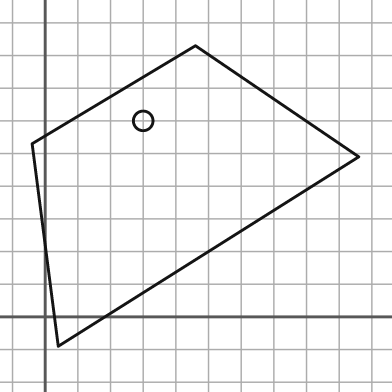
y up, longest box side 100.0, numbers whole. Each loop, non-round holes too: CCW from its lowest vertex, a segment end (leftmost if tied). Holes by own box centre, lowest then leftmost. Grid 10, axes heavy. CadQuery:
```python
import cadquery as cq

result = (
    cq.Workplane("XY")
    .moveTo(4.0, -9.0)
    .lineTo(96.0, 49.0)
    .lineTo(46.0, 83.0)
    .lineTo(-4.0, 53.0)
    .close()
    .moveTo(30.0, 60.0)
    .circle(3.0)
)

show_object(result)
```